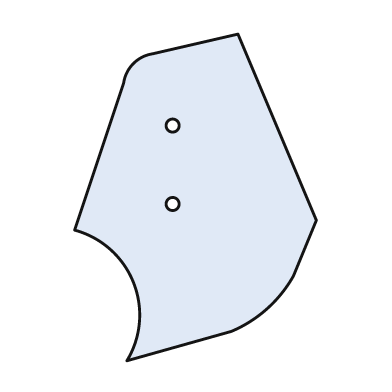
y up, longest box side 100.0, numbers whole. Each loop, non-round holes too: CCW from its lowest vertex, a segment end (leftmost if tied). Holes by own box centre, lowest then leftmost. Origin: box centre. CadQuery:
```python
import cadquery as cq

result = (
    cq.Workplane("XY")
    .moveTo(-21.0, -50.0)
    .lineTo(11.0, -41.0)
    .threePointArc((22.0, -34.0), (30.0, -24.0))
    .lineTo(37.0, -7.0)
    .lineTo(13.0, 50.0)
    .lineTo(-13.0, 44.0)
    .threePointArc((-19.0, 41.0), (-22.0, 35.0))
    .lineTo(-37.0, -10.0)
    .threePointArc((-19.0, -26.0), (-21.0, -50.0))
    .close()
    .moveTo(-7.0, -2.0)
    .circle(2.0)
    .moveTo(-7.0, 22.0)
    .circle(2.0)
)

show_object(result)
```